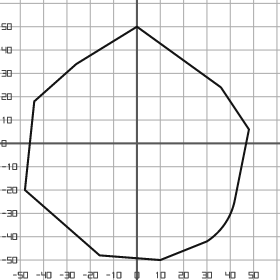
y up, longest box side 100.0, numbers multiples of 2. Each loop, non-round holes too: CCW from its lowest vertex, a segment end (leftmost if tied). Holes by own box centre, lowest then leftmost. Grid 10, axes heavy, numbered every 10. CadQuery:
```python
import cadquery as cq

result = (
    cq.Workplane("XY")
    .moveTo(10.0, -50.0)
    .lineTo(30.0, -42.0)
    .threePointArc((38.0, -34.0), (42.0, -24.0))
    .lineTo(48.0, 6.0)
    .lineTo(36.0, 24.0)
    .lineTo(0.0, 50.0)
    .lineTo(-26.0, 34.0)
    .lineTo(-44.0, 18.0)
    .lineTo(-48.0, -20.0)
    .lineTo(-16.0, -48.0)
    .close()
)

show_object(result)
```